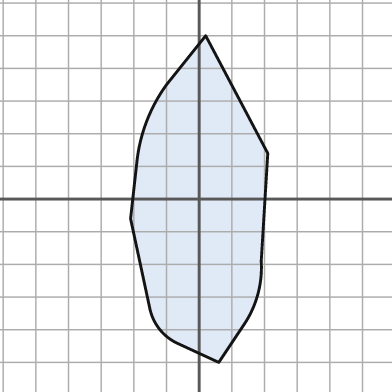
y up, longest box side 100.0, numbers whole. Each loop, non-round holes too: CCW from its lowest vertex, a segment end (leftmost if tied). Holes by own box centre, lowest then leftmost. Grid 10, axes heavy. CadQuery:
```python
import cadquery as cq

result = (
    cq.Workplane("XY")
    .moveTo(6.0, -50.0)
    .lineTo(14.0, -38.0)
    .threePointArc((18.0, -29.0), (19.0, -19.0))
    .lineTo(21.0, 14.0)
    .lineTo(2.0, 50.0)
    .lineTo(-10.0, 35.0)
    .threePointArc((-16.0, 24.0), (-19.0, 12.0))
    .lineTo(-21.0, -6.0)
    .lineTo(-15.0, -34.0)
    .threePointArc((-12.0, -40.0), (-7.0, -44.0))
    .close()
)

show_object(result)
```